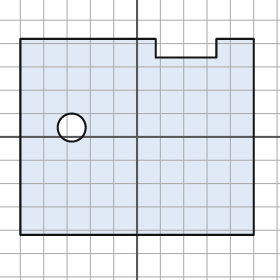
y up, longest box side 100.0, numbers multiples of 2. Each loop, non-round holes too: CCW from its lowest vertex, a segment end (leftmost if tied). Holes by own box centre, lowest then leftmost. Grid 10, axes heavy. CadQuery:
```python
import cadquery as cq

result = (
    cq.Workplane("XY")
    .moveTo(-50.0, -42.0)
    .lineTo(50.0, -42.0)
    .lineTo(50.0, 42.0)
    .lineTo(34.0, 42.0)
    .lineTo(34.0, 34.0)
    .lineTo(8.0, 34.0)
    .lineTo(8.0, 42.0)
    .lineTo(-50.0, 42.0)
    .close()
    .moveTo(-28.0, 4.0)
    .circle(6.0)
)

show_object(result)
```